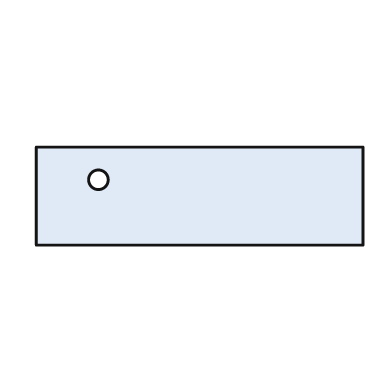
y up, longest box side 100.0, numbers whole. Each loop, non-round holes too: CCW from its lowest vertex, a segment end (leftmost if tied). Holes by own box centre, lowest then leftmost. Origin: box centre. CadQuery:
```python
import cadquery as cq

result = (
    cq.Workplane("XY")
    .moveTo(-50.0, -15.0)
    .lineTo(50.0, -15.0)
    .lineTo(50.0, 15.0)
    .lineTo(-50.0, 15.0)
    .close()
    .moveTo(-31.0, 5.0)
    .circle(3.0)
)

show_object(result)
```